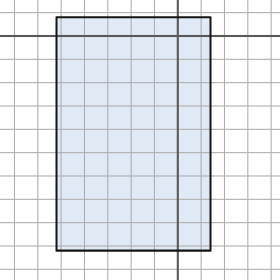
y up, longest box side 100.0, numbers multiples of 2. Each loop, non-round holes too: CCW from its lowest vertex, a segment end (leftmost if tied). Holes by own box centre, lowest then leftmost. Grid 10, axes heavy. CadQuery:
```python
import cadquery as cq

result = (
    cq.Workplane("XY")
    .moveTo(-52.0, -92.0)
    .lineTo(14.0, -92.0)
    .lineTo(14.0, 8.0)
    .lineTo(-52.0, 8.0)
    .close()
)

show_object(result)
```